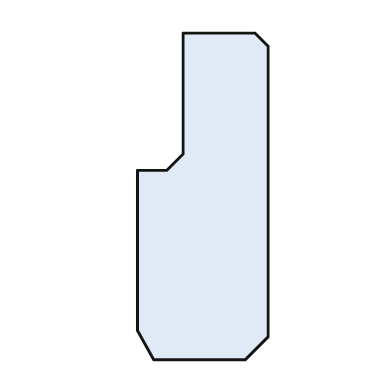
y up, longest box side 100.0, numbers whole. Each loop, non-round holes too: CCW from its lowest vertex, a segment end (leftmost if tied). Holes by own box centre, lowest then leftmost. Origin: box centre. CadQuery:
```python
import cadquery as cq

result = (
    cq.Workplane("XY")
    .moveTo(-15.0, -50.0)
    .lineTo(13.0, -50.0)
    .lineTo(20.0, -43.0)
    .lineTo(20.0, 46.0)
    .lineTo(16.0, 50.0)
    .lineTo(-6.0, 50.0)
    .lineTo(-6.0, 13.0)
    .lineTo(-11.0, 8.0)
    .lineTo(-20.0, 8.0)
    .lineTo(-20.0, -41.0)
    .close()
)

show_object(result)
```